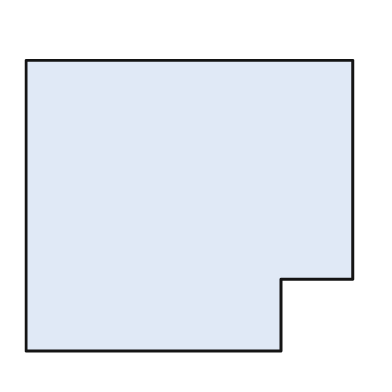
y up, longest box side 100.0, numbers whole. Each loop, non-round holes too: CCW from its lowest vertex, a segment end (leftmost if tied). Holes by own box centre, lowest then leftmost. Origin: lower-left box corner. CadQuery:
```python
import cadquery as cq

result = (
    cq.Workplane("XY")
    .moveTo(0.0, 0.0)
    .lineTo(78.0, 0.0)
    .lineTo(78.0, 22.0)
    .lineTo(100.0, 22.0)
    .lineTo(100.0, 89.0)
    .lineTo(0.0, 89.0)
    .close()
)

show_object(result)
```